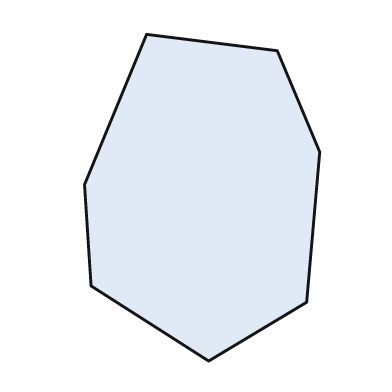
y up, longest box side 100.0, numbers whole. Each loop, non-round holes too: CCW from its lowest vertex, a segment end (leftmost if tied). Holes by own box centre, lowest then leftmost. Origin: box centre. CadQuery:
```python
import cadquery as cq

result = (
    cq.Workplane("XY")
    .moveTo(2.0, -50.0)
    .lineTo(32.0, -32.0)
    .lineTo(36.0, 14.0)
    .lineTo(23.0, 45.0)
    .lineTo(-17.0, 50.0)
    .lineTo(-36.0, 4.0)
    .lineTo(-34.0, -27.0)
    .close()
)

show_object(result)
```